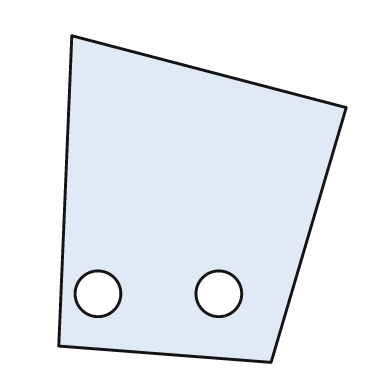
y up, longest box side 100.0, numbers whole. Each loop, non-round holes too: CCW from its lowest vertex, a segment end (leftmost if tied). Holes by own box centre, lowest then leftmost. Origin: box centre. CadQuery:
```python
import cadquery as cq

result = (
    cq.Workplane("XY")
    .moveTo(21.0, -50.0)
    .lineTo(44.0, 28.0)
    .lineTo(-40.0, 50.0)
    .lineTo(-44.0, -45.0)
    .close()
    .moveTo(-32.0, -29.0)
    .circle(7.0)
    .moveTo(5.0, -29.0)
    .circle(7.0)
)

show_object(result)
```